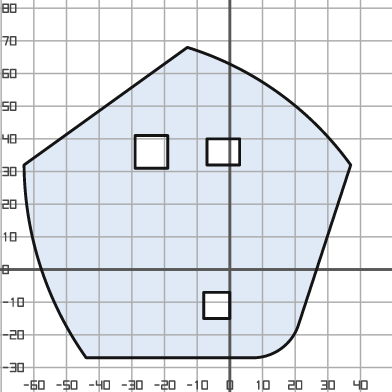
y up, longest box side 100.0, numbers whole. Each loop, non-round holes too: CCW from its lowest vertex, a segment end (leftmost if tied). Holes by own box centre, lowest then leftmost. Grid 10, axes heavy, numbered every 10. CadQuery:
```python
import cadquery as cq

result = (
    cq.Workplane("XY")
    .moveTo(-44.0, -27.0)
    .lineTo(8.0, -27.0)
    .threePointArc((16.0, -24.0), (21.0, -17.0))
    .lineTo(37.0, 32.0)
    .threePointArc((15.0, 54.0), (-13.0, 68.0))
    .lineTo(-63.0, 32.0)
    .threePointArc((-58.0, 1.0), (-44.0, -27.0))
    .close()
    .moveTo(-8.0, -15.0)
    .lineTo(0.0, -15.0)
    .lineTo(0.0, -7.0)
    .lineTo(-8.0, -7.0)
    .close()
    .moveTo(-29.0, 31.0)
    .lineTo(-19.0, 31.0)
    .lineTo(-19.0, 41.0)
    .lineTo(-29.0, 41.0)
    .close()
    .moveTo(-7.0, 32.0)
    .lineTo(3.0, 32.0)
    .lineTo(3.0, 40.0)
    .lineTo(-7.0, 40.0)
    .close()
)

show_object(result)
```